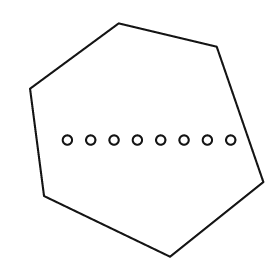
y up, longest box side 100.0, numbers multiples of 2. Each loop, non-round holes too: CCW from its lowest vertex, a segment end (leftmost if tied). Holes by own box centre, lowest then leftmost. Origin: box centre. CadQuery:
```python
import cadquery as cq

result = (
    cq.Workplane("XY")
    .moveTo(10.0, -50.0)
    .lineTo(50.0, -18.0)
    .lineTo(30.0, 40.0)
    .lineTo(-12.0, 50.0)
    .lineTo(-50.0, 22.0)
    .lineTo(-44.0, -24.0)
    .close()
    .moveTo(-34.0, 0.0)
    .circle(2.0)
    .moveTo(-24.0, 0.0)
    .circle(2.0)
    .moveTo(-14.0, 0.0)
    .circle(2.0)
    .moveTo(-4.0, 0.0)
    .circle(2.0)
    .moveTo(6.0, 0.0)
    .circle(2.0)
    .moveTo(16.0, 0.0)
    .circle(2.0)
    .moveTo(26.0, 0.0)
    .circle(2.0)
    .moveTo(36.0, 0.0)
    .circle(2.0)
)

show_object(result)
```